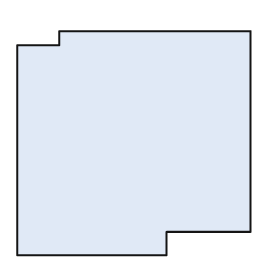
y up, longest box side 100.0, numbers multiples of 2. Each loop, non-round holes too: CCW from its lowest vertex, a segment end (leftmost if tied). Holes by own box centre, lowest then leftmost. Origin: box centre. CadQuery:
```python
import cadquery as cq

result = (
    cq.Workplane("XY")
    .moveTo(-50.0, -48.0)
    .lineTo(14.0, -48.0)
    .lineTo(14.0, -38.0)
    .lineTo(50.0, -38.0)
    .lineTo(50.0, 48.0)
    .lineTo(-32.0, 48.0)
    .lineTo(-32.0, 42.0)
    .lineTo(-50.0, 42.0)
    .close()
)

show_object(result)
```